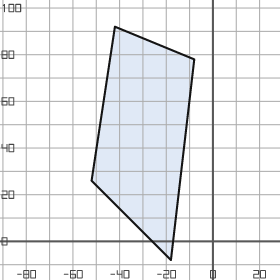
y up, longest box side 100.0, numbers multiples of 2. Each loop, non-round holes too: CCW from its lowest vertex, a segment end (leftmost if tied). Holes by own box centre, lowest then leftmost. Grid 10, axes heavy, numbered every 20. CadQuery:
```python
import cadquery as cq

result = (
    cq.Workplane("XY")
    .moveTo(-18.0, -8.0)
    .lineTo(-8.0, 78.0)
    .lineTo(-42.0, 92.0)
    .lineTo(-52.0, 26.0)
    .close()
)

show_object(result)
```